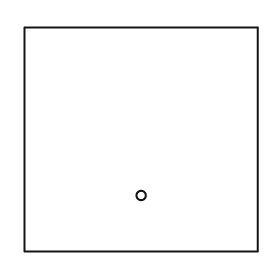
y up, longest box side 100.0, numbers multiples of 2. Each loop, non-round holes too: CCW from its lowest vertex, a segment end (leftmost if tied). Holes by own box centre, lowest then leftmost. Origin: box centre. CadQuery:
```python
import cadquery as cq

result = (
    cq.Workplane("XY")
    .moveTo(-50.0, -48.0)
    .lineTo(50.0, -48.0)
    .lineTo(50.0, 48.0)
    .lineTo(-50.0, 48.0)
    .close()
    .moveTo(0.0, -24.0)
    .circle(2.0)
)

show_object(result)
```